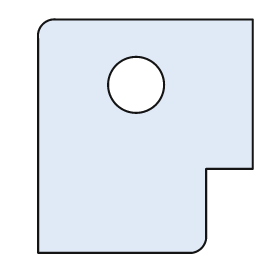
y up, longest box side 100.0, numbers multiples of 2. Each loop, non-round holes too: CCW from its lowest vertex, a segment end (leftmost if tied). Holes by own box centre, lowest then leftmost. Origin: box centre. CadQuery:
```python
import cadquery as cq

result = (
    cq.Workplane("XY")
    .moveTo(-46.0, -50.0)
    .lineTo(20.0, -50.0)
    .threePointArc((24.0, -48.0), (26.0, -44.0))
    .lineTo(26.0, -14.0)
    .lineTo(46.0, -14.0)
    .lineTo(46.0, 50.0)
    .lineTo(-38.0, 50.0)
    .threePointArc((-44.0, 48.0), (-46.0, 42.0))
    .close()
    .moveTo(-4.0, 22.0)
    .circle(12.0)
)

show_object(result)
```